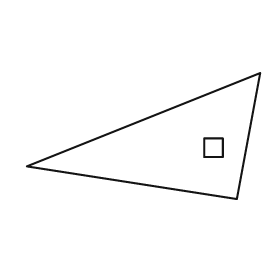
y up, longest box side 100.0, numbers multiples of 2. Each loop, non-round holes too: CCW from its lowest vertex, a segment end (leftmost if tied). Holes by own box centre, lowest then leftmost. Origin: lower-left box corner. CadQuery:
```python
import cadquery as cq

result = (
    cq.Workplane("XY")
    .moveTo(90.0, 0.0)
    .lineTo(100.0, 54.0)
    .lineTo(0.0, 14.0)
    .close()
    .moveTo(76.0, 18.0)
    .lineTo(84.0, 18.0)
    .lineTo(84.0, 26.0)
    .lineTo(76.0, 26.0)
    .close()
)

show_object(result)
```